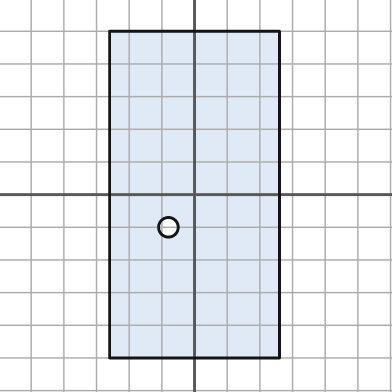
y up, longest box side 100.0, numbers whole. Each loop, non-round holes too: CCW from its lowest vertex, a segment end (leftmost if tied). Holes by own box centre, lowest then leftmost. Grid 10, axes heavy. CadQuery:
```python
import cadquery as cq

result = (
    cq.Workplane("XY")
    .moveTo(-26.0, -50.0)
    .lineTo(26.0, -50.0)
    .lineTo(26.0, 50.0)
    .lineTo(-26.0, 50.0)
    .close()
    .moveTo(-8.0, -10.0)
    .circle(3.0)
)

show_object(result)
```